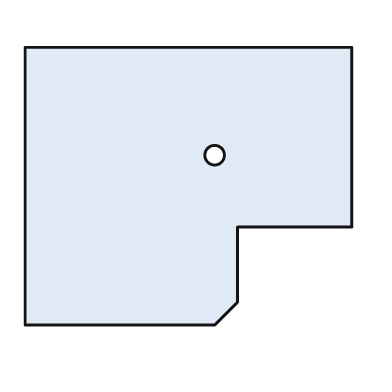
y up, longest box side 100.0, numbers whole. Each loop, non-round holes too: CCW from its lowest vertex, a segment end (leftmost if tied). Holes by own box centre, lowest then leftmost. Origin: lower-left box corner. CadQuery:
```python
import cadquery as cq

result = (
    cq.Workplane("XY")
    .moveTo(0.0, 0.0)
    .lineTo(58.0, 0.0)
    .lineTo(65.0, 7.0)
    .lineTo(65.0, 30.0)
    .lineTo(100.0, 30.0)
    .lineTo(100.0, 85.0)
    .lineTo(0.0, 85.0)
    .close()
    .moveTo(58.0, 52.0)
    .circle(3.0)
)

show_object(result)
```